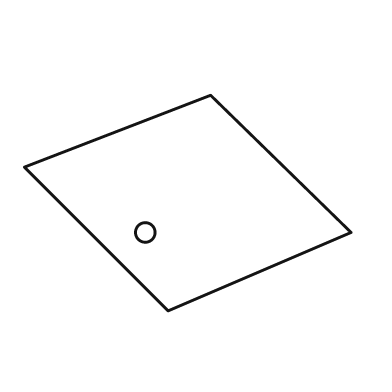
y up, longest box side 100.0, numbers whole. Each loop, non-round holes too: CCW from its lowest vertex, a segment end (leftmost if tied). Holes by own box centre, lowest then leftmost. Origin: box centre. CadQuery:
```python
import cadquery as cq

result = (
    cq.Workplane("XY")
    .moveTo(-6.0, -33.0)
    .lineTo(50.0, -9.0)
    .lineTo(7.0, 33.0)
    .lineTo(-50.0, 11.0)
    .close()
    .moveTo(-13.0, -9.0)
    .circle(3.0)
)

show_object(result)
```